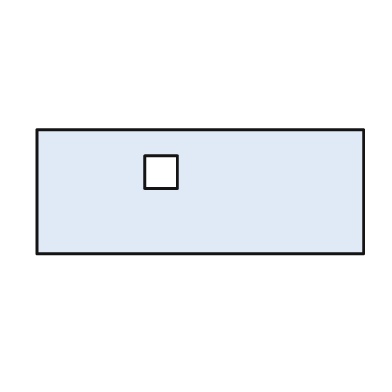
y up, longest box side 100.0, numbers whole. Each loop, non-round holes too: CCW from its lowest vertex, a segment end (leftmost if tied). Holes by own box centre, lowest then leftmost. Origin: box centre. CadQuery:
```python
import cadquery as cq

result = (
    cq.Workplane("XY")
    .moveTo(-50.0, -19.0)
    .lineTo(50.0, -19.0)
    .lineTo(50.0, 19.0)
    .lineTo(-50.0, 19.0)
    .close()
    .moveTo(-17.0, 1.0)
    .lineTo(-7.0, 1.0)
    .lineTo(-7.0, 11.0)
    .lineTo(-17.0, 11.0)
    .close()
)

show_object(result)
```